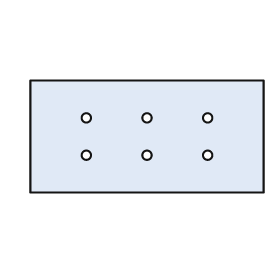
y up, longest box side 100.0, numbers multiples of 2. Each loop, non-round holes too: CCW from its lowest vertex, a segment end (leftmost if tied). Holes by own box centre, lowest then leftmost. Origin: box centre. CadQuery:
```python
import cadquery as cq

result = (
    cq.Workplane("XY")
    .moveTo(-50.0, -24.0)
    .lineTo(50.0, -24.0)
    .lineTo(50.0, 24.0)
    .lineTo(-50.0, 24.0)
    .close()
    .moveTo(-26.0, -8.0)
    .circle(2.0)
    .moveTo(0.0, -8.0)
    .circle(2.0)
    .moveTo(26.0, -8.0)
    .circle(2.0)
    .moveTo(-26.0, 8.0)
    .circle(2.0)
    .moveTo(0.0, 8.0)
    .circle(2.0)
    .moveTo(26.0, 8.0)
    .circle(2.0)
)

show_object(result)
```